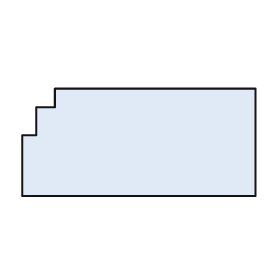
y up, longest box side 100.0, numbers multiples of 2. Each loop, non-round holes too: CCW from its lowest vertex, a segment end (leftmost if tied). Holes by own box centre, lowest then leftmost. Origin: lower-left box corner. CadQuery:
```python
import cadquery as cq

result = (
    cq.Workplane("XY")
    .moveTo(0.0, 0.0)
    .lineTo(100.0, 0.0)
    .lineTo(100.0, 46.0)
    .lineTo(14.0, 46.0)
    .lineTo(14.0, 38.0)
    .lineTo(6.0, 38.0)
    .lineTo(6.0, 26.0)
    .lineTo(0.0, 26.0)
    .close()
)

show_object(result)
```